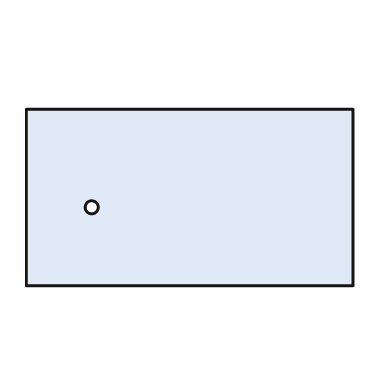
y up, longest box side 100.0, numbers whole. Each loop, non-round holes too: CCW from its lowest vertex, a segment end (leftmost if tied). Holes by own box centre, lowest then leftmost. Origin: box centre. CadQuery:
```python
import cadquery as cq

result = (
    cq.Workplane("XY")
    .moveTo(-50.0, -27.0)
    .lineTo(50.0, -27.0)
    .lineTo(50.0, 27.0)
    .lineTo(-50.0, 27.0)
    .close()
    .moveTo(-30.0, -3.0)
    .circle(2.0)
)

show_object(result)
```